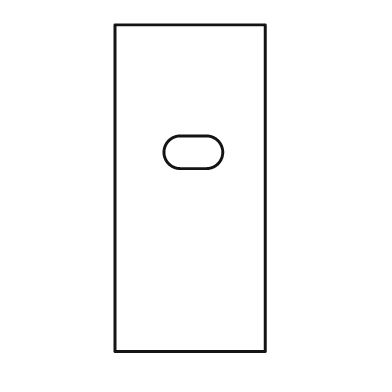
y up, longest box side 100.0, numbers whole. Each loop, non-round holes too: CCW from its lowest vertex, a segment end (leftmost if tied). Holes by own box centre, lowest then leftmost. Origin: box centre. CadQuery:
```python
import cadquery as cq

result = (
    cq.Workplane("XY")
    .moveTo(-23.0, -50.0)
    .lineTo(23.0, -50.0)
    .lineTo(23.0, 50.0)
    .lineTo(-23.0, 50.0)
    .close()
    .moveTo(-3.0, 6.0)
    .lineTo(5.0, 6.0)
    .threePointArc((10.0, 11.0), (5.0, 16.0))
    .lineTo(-3.0, 16.0)
    .threePointArc((-8.0, 11.0), (-3.0, 6.0))
    .close()
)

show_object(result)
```